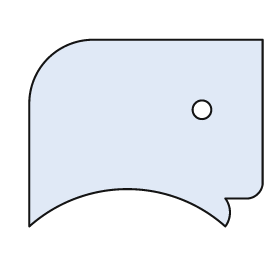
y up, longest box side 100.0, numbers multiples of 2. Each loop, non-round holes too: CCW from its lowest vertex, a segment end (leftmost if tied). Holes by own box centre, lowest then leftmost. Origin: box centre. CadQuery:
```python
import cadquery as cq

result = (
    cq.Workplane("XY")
    .moveTo(-50.0, -40.0)
    .threePointArc((-8.0, -24.0), (34.0, -40.0))
    .threePointArc((36.0, -34.0), (34.0, -28.0))
    .lineTo(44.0, -28.0)
    .threePointArc((48.0, -26.0), (50.0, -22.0))
    .lineTo(50.0, 40.0)
    .lineTo(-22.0, 40.0)
    .threePointArc((-42.0, 32.0), (-50.0, 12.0))
    .close()
    .moveTo(24.0, 10.0)
    .circle(4.0)
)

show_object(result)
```